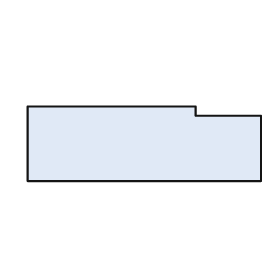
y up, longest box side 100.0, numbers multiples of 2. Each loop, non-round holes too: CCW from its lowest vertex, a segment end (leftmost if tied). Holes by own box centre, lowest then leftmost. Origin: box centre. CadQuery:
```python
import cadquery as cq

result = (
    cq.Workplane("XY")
    .moveTo(-50.0, -16.0)
    .lineTo(50.0, -16.0)
    .lineTo(50.0, 12.0)
    .lineTo(22.0, 12.0)
    .lineTo(22.0, 16.0)
    .lineTo(-50.0, 16.0)
    .close()
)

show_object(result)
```